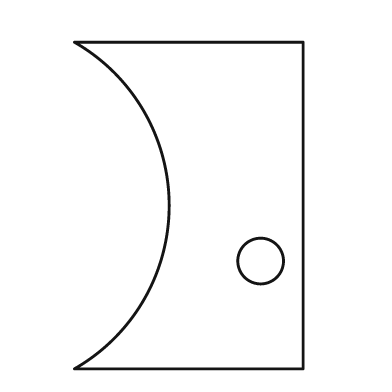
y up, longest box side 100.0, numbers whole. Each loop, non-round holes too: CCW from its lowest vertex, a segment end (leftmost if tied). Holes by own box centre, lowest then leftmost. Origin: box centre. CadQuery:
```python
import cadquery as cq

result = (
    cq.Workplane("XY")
    .moveTo(-35.0, -50.0)
    .lineTo(35.0, -50.0)
    .lineTo(35.0, 50.0)
    .lineTo(-35.0, 50.0)
    .threePointArc((-6.0, 0.0), (-35.0, -50.0))
    .close()
    .moveTo(22.0, -17.0)
    .circle(7.0)
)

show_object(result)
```